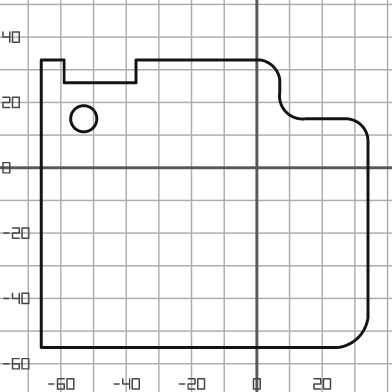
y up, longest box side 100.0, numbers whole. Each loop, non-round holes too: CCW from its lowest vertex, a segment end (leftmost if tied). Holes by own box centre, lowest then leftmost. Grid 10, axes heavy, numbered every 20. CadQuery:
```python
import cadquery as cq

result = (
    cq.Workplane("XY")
    .moveTo(-66.0, -55.0)
    .lineTo(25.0, -55.0)
    .threePointArc((31.0, -52.0), (34.0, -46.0))
    .lineTo(34.0, 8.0)
    .threePointArc((32.0, 13.0), (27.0, 15.0))
    .lineTo(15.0, 15.0)
    .threePointArc((9.0, 17.0), (7.0, 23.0))
    .lineTo(7.0, 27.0)
    .threePointArc((5.0, 31.0), (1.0, 33.0))
    .lineTo(-37.0, 33.0)
    .lineTo(-37.0, 26.0)
    .lineTo(-59.0, 26.0)
    .lineTo(-59.0, 33.0)
    .lineTo(-66.0, 33.0)
    .close()
    .moveTo(-53.0, 15.0)
    .circle(4.0)
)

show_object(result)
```